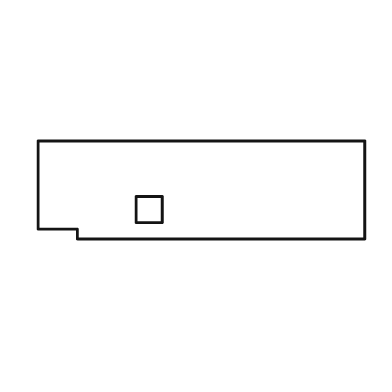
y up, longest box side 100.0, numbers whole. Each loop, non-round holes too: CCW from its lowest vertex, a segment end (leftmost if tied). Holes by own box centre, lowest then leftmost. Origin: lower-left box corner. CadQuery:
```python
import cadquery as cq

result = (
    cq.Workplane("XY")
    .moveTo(12.0, 0.0)
    .lineTo(100.0, 0.0)
    .lineTo(100.0, 30.0)
    .lineTo(0.0, 30.0)
    .lineTo(0.0, 3.0)
    .lineTo(12.0, 3.0)
    .close()
    .moveTo(30.0, 5.0)
    .lineTo(38.0, 5.0)
    .lineTo(38.0, 13.0)
    .lineTo(30.0, 13.0)
    .close()
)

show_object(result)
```